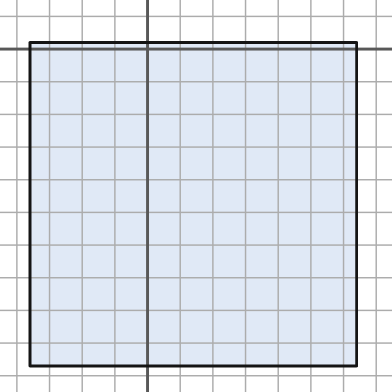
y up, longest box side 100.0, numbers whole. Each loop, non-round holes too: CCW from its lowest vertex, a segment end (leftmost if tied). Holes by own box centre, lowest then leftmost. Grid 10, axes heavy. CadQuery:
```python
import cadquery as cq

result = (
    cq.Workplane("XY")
    .moveTo(-36.0, -97.0)
    .lineTo(64.0, -97.0)
    .lineTo(64.0, 2.0)
    .lineTo(-36.0, 2.0)
    .close()
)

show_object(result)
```